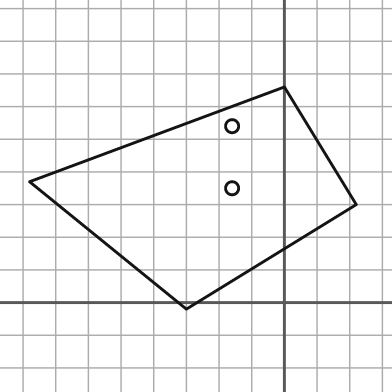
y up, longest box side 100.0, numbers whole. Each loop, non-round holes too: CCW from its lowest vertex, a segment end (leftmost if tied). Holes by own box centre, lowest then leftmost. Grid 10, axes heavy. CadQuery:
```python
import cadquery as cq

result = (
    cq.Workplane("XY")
    .moveTo(-30.0, -2.0)
    .lineTo(22.0, 30.0)
    .lineTo(0.0, 66.0)
    .lineTo(-78.0, 37.0)
    .close()
    .moveTo(-16.0, 35.0)
    .circle(2.0)
    .moveTo(-16.0, 54.0)
    .circle(2.0)
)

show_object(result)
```